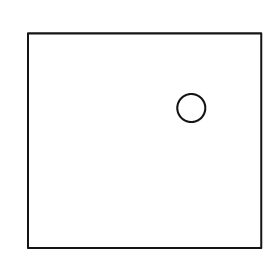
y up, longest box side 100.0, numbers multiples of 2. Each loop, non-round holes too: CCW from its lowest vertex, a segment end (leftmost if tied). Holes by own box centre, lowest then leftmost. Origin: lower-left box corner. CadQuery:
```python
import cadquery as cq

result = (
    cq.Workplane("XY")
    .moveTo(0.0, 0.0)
    .lineTo(100.0, 0.0)
    .lineTo(100.0, 92.0)
    .lineTo(0.0, 92.0)
    .close()
    .moveTo(70.0, 60.0)
    .circle(6.0)
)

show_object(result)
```